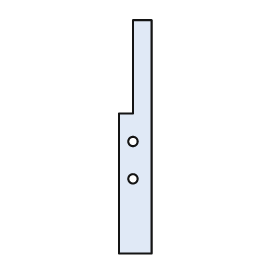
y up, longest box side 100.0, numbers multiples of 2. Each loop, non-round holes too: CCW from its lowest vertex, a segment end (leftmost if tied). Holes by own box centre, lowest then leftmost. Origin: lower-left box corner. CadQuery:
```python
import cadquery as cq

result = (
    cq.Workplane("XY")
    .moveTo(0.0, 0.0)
    .lineTo(14.0, 0.0)
    .lineTo(14.0, 100.0)
    .lineTo(6.0, 100.0)
    .lineTo(6.0, 60.0)
    .lineTo(0.0, 60.0)
    .close()
    .moveTo(6.0, 32.0)
    .circle(2.0)
    .moveTo(6.0, 48.0)
    .circle(2.0)
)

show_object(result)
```